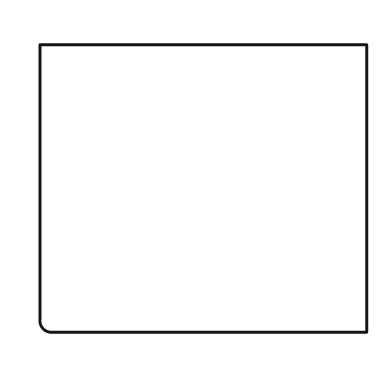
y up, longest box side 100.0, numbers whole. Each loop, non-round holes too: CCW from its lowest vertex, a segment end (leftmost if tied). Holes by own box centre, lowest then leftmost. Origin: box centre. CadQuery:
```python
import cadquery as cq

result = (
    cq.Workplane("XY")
    .moveTo(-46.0, -44.0)
    .lineTo(50.0, -44.0)
    .lineTo(50.0, 44.0)
    .lineTo(-50.0, 44.0)
    .lineTo(-50.0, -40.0)
    .threePointArc((-49.0, -43.0), (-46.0, -44.0))
    .close()
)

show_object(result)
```